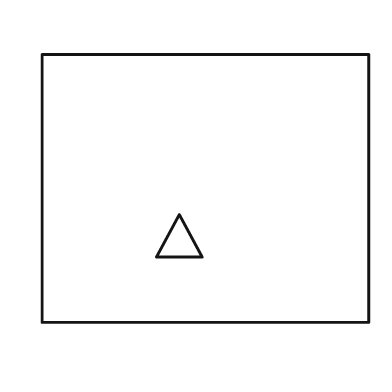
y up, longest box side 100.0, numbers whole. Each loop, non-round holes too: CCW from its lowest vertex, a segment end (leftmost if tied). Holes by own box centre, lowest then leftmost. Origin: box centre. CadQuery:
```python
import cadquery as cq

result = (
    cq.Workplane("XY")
    .moveTo(-50.0, -41.0)
    .lineTo(50.0, -41.0)
    .lineTo(50.0, 41.0)
    .lineTo(-50.0, 41.0)
    .close()
    .moveTo(-15.0, -21.0)
    .lineTo(-1.0, -21.0)
    .lineTo(-8.0, -8.0)
    .close()
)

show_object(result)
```